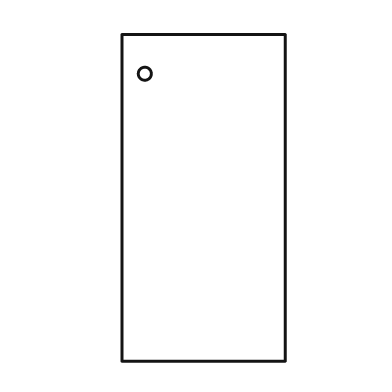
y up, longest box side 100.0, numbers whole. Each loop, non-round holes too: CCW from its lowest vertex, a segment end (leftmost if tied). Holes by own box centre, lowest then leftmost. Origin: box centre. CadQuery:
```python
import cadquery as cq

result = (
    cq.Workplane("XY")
    .moveTo(-25.0, -50.0)
    .lineTo(25.0, -50.0)
    .lineTo(25.0, 50.0)
    .lineTo(-25.0, 50.0)
    .close()
    .moveTo(-18.0, 38.0)
    .circle(2.0)
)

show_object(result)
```